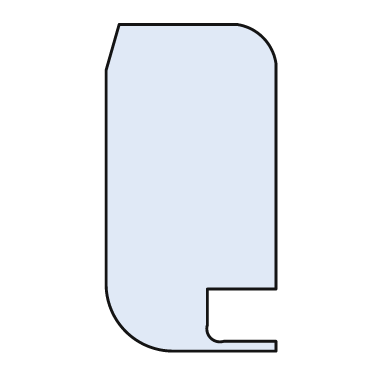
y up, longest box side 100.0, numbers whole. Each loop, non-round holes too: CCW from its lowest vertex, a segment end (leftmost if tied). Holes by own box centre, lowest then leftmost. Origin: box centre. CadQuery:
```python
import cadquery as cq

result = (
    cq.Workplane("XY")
    .moveTo(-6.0, -50.0)
    .lineTo(26.0, -50.0)
    .lineTo(26.0, -47.0)
    .lineTo(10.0, -47.0)
    .threePointArc((6.0, -46.0), (5.0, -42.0))
    .lineTo(5.0, -31.0)
    .lineTo(26.0, -31.0)
    .lineTo(26.0, 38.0)
    .threePointArc((22.0, 46.0), (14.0, 50.0))
    .lineTo(-22.0, 50.0)
    .lineTo(-26.0, 36.0)
    .lineTo(-26.0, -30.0)
    .threePointArc((-20.0, -44.0), (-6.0, -50.0))
    .close()
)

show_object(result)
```